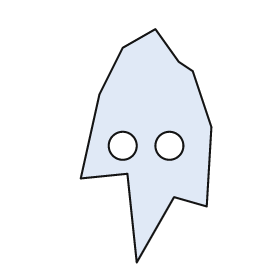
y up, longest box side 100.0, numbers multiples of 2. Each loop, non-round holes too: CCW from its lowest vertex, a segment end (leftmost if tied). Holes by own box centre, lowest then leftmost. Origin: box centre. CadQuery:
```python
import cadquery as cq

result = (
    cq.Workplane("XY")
    .moveTo(-4.0, -50.0)
    .lineTo(12.0, -22.0)
    .lineTo(26.0, -26.0)
    .lineTo(28.0, 8.0)
    .lineTo(20.0, 32.0)
    .lineTo(14.0, 36.0)
    .lineTo(4.0, 50.0)
    .lineTo(-10.0, 42.0)
    .lineTo(-20.0, 22.0)
    .lineTo(-28.0, -14.0)
    .lineTo(-8.0, -12.0)
    .close()
    .moveTo(-10.0, 0.0)
    .circle(6.0)
    .moveTo(10.0, 0.0)
    .circle(6.0)
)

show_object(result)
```